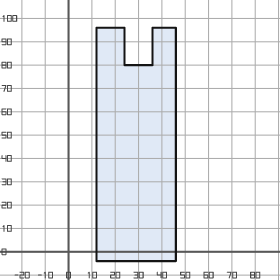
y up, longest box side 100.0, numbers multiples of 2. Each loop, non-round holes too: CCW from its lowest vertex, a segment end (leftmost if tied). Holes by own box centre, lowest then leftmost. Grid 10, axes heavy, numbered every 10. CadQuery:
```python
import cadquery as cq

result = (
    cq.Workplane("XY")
    .moveTo(12.0, -4.0)
    .lineTo(46.0, -4.0)
    .lineTo(46.0, 96.0)
    .lineTo(36.0, 96.0)
    .lineTo(36.0, 80.0)
    .lineTo(24.0, 80.0)
    .lineTo(24.0, 96.0)
    .lineTo(12.0, 96.0)
    .close()
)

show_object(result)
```